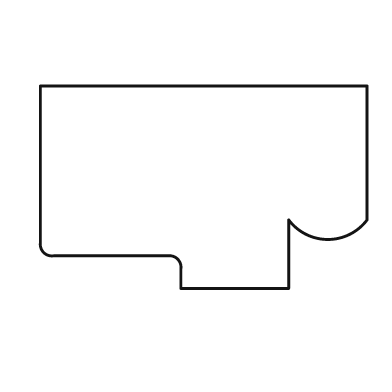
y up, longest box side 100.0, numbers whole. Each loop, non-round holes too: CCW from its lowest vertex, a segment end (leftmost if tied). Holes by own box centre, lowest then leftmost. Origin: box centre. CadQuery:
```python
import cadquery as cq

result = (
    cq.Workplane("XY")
    .moveTo(-7.0, -31.0)
    .lineTo(26.0, -31.0)
    .lineTo(26.0, -10.0)
    .threePointArc((38.0, -16.0), (50.0, -10.0))
    .lineTo(50.0, 31.0)
    .lineTo(-50.0, 31.0)
    .lineTo(-50.0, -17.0)
    .threePointArc((-49.0, -20.0), (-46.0, -21.0))
    .lineTo(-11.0, -21.0)
    .threePointArc((-8.0, -22.0), (-7.0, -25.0))
    .close()
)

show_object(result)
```